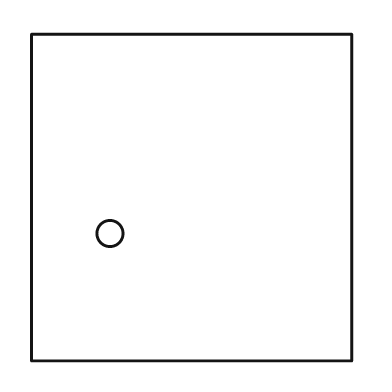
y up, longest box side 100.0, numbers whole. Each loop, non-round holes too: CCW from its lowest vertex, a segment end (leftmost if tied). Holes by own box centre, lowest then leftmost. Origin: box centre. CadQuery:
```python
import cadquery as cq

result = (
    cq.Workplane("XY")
    .moveTo(-49.0, -50.0)
    .lineTo(49.0, -50.0)
    .lineTo(49.0, 50.0)
    .lineTo(-49.0, 50.0)
    .close()
    .moveTo(-25.0, -11.0)
    .circle(4.0)
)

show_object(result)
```